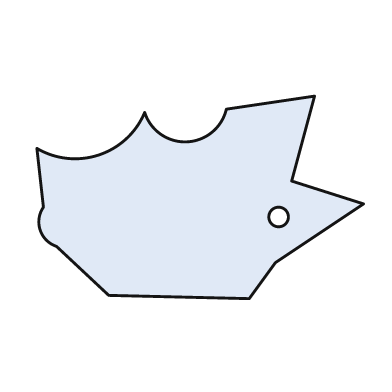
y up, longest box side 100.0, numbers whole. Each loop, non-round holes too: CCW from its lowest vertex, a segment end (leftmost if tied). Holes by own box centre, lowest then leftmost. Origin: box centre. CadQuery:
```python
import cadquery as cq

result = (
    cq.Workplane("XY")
    .moveTo(15.0, -31.0)
    .lineTo(23.0, -20.0)
    .lineTo(50.0, -2.0)
    .lineTo(28.0, 5.0)
    .lineTo(35.0, 31.0)
    .lineTo(8.0, 27.0)
    .threePointArc((-4.0, 17.0), (-17.0, 26.0))
    .threePointArc((-31.0, 13.0), (-50.0, 15.0))
    .lineTo(-48.0, -3.0)
    .threePointArc((-49.0, -10.0), (-44.0, -15.0))
    .lineTo(-28.0, -30.0)
    .close()
    .moveTo(24.0, -6.0)
    .circle(3.0)
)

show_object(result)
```